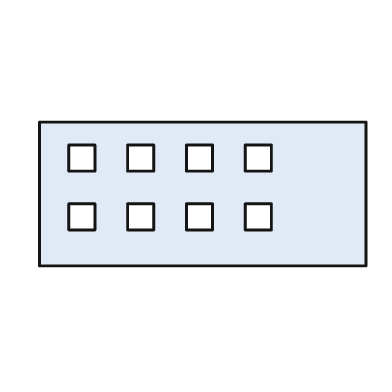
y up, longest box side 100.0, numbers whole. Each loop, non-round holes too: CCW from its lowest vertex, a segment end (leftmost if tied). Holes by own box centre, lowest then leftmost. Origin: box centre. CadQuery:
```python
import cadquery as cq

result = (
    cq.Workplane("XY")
    .moveTo(-50.0, -22.0)
    .lineTo(50.0, -22.0)
    .lineTo(50.0, 22.0)
    .lineTo(-50.0, 22.0)
    .close()
    .moveTo(-41.0, -11.0)
    .lineTo(-33.0, -11.0)
    .lineTo(-33.0, -3.0)
    .lineTo(-41.0, -3.0)
    .close()
    .moveTo(-23.0, -11.0)
    .lineTo(-15.0, -11.0)
    .lineTo(-15.0, -3.0)
    .lineTo(-23.0, -3.0)
    .close()
    .moveTo(-5.0, -11.0)
    .lineTo(3.0, -11.0)
    .lineTo(3.0, -3.0)
    .lineTo(-5.0, -3.0)
    .close()
    .moveTo(13.0, -11.0)
    .lineTo(21.0, -11.0)
    .lineTo(21.0, -3.0)
    .lineTo(13.0, -3.0)
    .close()
    .moveTo(-41.0, 7.0)
    .lineTo(-33.0, 7.0)
    .lineTo(-33.0, 15.0)
    .lineTo(-41.0, 15.0)
    .close()
    .moveTo(-23.0, 7.0)
    .lineTo(-15.0, 7.0)
    .lineTo(-15.0, 15.0)
    .lineTo(-23.0, 15.0)
    .close()
    .moveTo(-5.0, 7.0)
    .lineTo(3.0, 7.0)
    .lineTo(3.0, 15.0)
    .lineTo(-5.0, 15.0)
    .close()
    .moveTo(13.0, 7.0)
    .lineTo(21.0, 7.0)
    .lineTo(21.0, 15.0)
    .lineTo(13.0, 15.0)
    .close()
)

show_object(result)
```